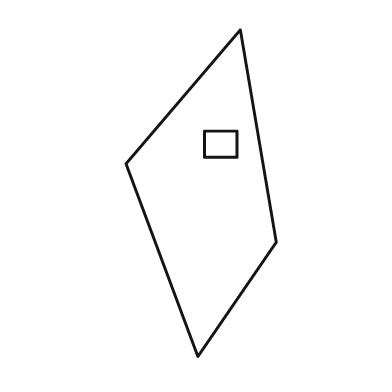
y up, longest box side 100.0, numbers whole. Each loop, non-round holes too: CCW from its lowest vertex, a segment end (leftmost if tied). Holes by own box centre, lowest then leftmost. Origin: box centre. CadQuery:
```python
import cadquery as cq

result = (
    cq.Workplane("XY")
    .moveTo(-1.0, -50.0)
    .lineTo(23.0, -15.0)
    .lineTo(12.0, 50.0)
    .lineTo(-23.0, 9.0)
    .close()
    .moveTo(1.0, 11.0)
    .lineTo(11.0, 11.0)
    .lineTo(11.0, 19.0)
    .lineTo(1.0, 19.0)
    .close()
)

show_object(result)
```